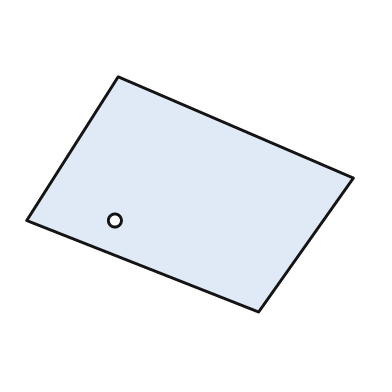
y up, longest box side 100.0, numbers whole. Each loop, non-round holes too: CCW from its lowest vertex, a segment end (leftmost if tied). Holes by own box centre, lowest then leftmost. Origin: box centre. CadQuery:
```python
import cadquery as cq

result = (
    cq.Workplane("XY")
    .moveTo(21.0, -36.0)
    .lineTo(50.0, 5.0)
    .lineTo(-22.0, 36.0)
    .lineTo(-50.0, -8.0)
    .close()
    .moveTo(-23.0, -8.0)
    .circle(2.0)
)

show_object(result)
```